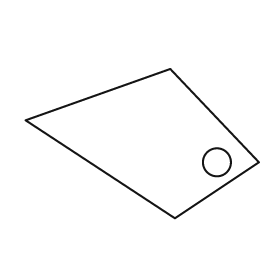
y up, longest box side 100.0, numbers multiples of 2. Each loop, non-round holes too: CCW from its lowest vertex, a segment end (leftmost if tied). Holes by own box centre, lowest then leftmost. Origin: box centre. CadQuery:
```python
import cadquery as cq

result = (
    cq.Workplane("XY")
    .moveTo(14.0, -32.0)
    .lineTo(50.0, -8.0)
    .lineTo(12.0, 32.0)
    .lineTo(-50.0, 10.0)
    .close()
    .moveTo(32.0, -8.0)
    .circle(6.0)
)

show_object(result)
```